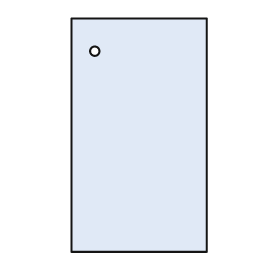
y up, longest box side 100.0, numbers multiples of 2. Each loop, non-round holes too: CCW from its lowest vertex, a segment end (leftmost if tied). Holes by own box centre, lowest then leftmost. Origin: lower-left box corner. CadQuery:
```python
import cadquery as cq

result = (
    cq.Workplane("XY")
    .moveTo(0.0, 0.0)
    .lineTo(58.0, 0.0)
    .lineTo(58.0, 100.0)
    .lineTo(0.0, 100.0)
    .close()
    .moveTo(10.0, 86.0)
    .circle(2.0)
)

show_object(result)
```